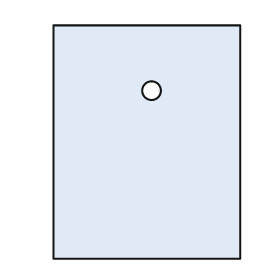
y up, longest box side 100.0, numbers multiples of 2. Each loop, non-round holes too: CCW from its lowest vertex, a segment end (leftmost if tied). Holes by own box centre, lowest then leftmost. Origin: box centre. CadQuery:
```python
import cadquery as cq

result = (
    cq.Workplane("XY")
    .moveTo(-40.0, -50.0)
    .lineTo(40.0, -50.0)
    .lineTo(40.0, 50.0)
    .lineTo(-40.0, 50.0)
    .close()
    .moveTo(2.0, 22.0)
    .circle(4.0)
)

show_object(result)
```